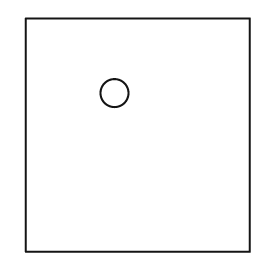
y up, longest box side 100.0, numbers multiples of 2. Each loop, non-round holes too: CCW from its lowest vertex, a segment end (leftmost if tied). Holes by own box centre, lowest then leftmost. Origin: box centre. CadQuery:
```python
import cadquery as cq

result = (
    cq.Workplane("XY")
    .moveTo(-48.0, -50.0)
    .lineTo(48.0, -50.0)
    .lineTo(48.0, 50.0)
    .lineTo(-48.0, 50.0)
    .close()
    .moveTo(-10.0, 18.0)
    .circle(6.0)
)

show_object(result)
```